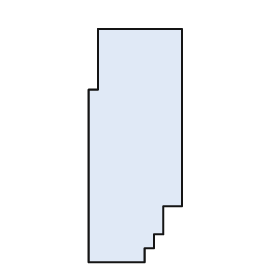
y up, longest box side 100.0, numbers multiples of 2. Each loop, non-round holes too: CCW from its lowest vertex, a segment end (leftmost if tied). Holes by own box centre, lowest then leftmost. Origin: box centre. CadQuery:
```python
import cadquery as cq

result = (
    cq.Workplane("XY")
    .moveTo(-20.0, -50.0)
    .lineTo(4.0, -50.0)
    .lineTo(4.0, -44.0)
    .lineTo(8.0, -44.0)
    .lineTo(8.0, -38.0)
    .lineTo(12.0, -38.0)
    .lineTo(12.0, -26.0)
    .lineTo(20.0, -26.0)
    .lineTo(20.0, 50.0)
    .lineTo(-16.0, 50.0)
    .lineTo(-16.0, 24.0)
    .lineTo(-20.0, 24.0)
    .close()
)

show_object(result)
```